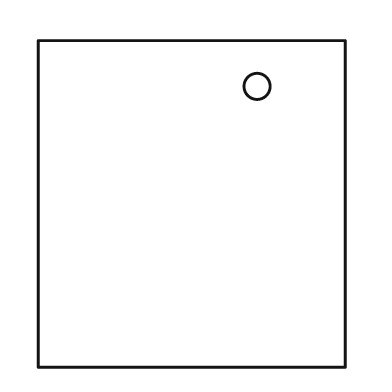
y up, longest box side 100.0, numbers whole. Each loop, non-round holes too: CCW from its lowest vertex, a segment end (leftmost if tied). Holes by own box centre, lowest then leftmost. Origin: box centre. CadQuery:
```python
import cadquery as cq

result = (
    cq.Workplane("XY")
    .moveTo(-47.0, -50.0)
    .lineTo(47.0, -50.0)
    .lineTo(47.0, 50.0)
    .lineTo(-47.0, 50.0)
    .close()
    .moveTo(20.0, 36.0)
    .circle(4.0)
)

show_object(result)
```